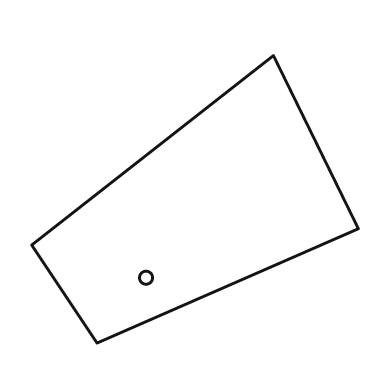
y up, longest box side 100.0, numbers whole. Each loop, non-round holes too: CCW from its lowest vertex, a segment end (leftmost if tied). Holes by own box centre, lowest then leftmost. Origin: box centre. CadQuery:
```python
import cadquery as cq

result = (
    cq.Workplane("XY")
    .moveTo(-30.0, -44.0)
    .lineTo(50.0, -9.0)
    .lineTo(24.0, 44.0)
    .lineTo(-50.0, -14.0)
    .close()
    .moveTo(-15.0, -24.0)
    .circle(2.0)
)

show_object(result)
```